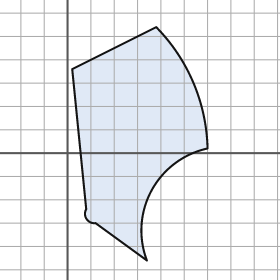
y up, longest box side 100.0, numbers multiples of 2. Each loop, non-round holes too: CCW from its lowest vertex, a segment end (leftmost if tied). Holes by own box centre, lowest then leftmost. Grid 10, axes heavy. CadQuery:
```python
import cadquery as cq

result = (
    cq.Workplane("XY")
    .moveTo(34.0, -46.0)
    .threePointArc((36.0, -16.0), (60.0, 2.0))
    .threePointArc((54.0, 30.0), (38.0, 54.0))
    .lineTo(2.0, 36.0)
    .lineTo(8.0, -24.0)
    .threePointArc((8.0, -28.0), (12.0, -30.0))
    .close()
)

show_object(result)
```